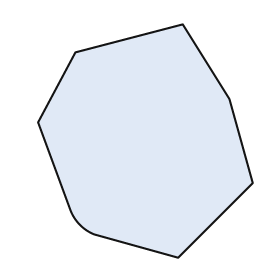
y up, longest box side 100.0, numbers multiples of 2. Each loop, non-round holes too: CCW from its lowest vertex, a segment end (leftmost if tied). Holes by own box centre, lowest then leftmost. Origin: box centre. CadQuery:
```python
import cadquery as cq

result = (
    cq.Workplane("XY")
    .moveTo(14.0, -50.0)
    .lineTo(46.0, -18.0)
    .lineTo(36.0, 18.0)
    .lineTo(16.0, 50.0)
    .lineTo(-30.0, 38.0)
    .lineTo(-46.0, 8.0)
    .lineTo(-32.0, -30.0)
    .threePointArc((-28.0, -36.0), (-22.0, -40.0))
    .close()
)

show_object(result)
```